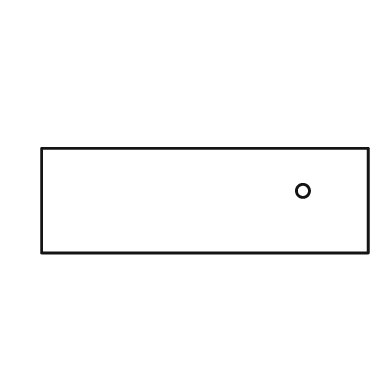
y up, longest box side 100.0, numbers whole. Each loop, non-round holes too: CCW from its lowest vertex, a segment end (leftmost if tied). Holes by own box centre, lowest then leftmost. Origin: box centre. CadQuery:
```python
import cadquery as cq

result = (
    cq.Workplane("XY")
    .moveTo(-50.0, -16.0)
    .lineTo(50.0, -16.0)
    .lineTo(50.0, 16.0)
    .lineTo(-50.0, 16.0)
    .close()
    .moveTo(30.0, 3.0)
    .circle(2.0)
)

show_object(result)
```